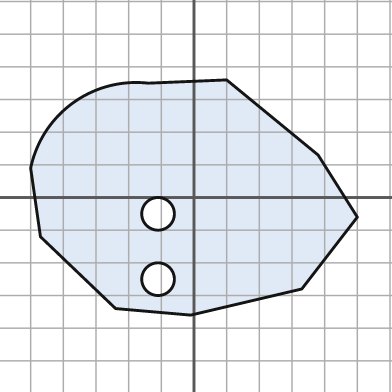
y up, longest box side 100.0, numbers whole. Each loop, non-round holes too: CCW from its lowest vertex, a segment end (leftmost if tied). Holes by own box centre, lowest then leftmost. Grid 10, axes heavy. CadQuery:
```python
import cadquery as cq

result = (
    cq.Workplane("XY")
    .moveTo(-1.0, -36.0)
    .lineTo(33.0, -28.0)
    .lineTo(50.0, -6.0)
    .lineTo(38.0, 13.0)
    .lineTo(10.0, 36.0)
    .lineTo(-14.0, 35.0)
    .threePointArc((-37.0, 29.0), (-50.0, 9.0))
    .lineTo(-47.0, -12.0)
    .lineTo(-24.0, -34.0)
    .close()
    .moveTo(-11.0, -25.0)
    .circle(5.0)
    .moveTo(-11.0, -5.0)
    .circle(5.0)
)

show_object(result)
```